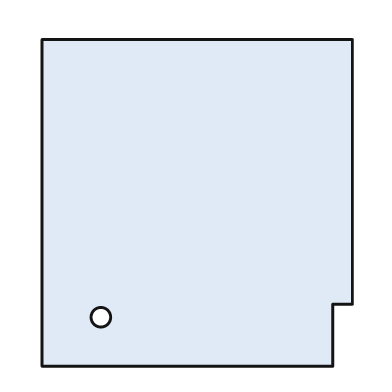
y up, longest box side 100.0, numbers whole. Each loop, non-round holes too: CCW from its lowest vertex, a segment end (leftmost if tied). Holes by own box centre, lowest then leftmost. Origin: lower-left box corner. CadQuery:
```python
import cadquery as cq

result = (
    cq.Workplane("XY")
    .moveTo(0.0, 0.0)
    .lineTo(89.0, 0.0)
    .lineTo(89.0, 19.0)
    .lineTo(95.0, 19.0)
    .lineTo(95.0, 100.0)
    .lineTo(0.0, 100.0)
    .close()
    .moveTo(18.0, 15.0)
    .circle(3.0)
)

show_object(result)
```